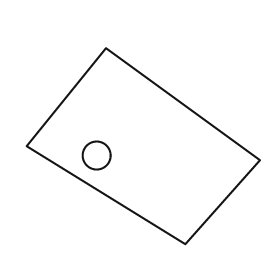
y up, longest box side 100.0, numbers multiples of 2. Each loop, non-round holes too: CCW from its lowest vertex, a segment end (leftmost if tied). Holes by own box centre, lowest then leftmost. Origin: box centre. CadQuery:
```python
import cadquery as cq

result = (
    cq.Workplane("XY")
    .moveTo(18.0, -42.0)
    .lineTo(50.0, -6.0)
    .lineTo(-16.0, 42.0)
    .lineTo(-50.0, 0.0)
    .close()
    .moveTo(-20.0, -4.0)
    .circle(6.0)
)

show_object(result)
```